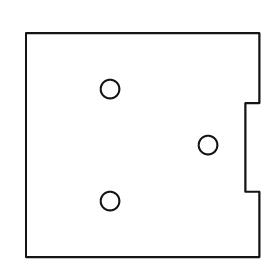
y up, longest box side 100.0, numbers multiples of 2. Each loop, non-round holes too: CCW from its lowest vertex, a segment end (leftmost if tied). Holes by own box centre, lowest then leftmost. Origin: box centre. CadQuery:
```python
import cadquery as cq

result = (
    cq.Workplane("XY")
    .moveTo(-50.0, -48.0)
    .lineTo(50.0, -48.0)
    .lineTo(50.0, -20.0)
    .lineTo(44.0, -20.0)
    .lineTo(44.0, 18.0)
    .lineTo(50.0, 18.0)
    .lineTo(50.0, 48.0)
    .lineTo(-50.0, 48.0)
    .close()
    .moveTo(-14.0, -24.0)
    .circle(4.0)
    .moveTo(28.0, 0.0)
    .circle(4.0)
    .moveTo(-14.0, 24.0)
    .circle(4.0)
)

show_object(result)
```